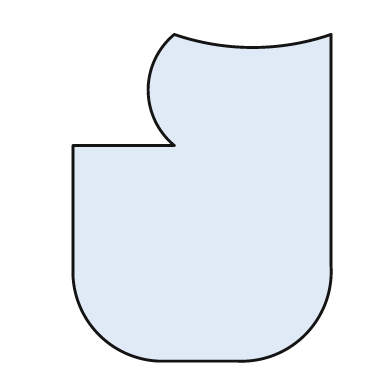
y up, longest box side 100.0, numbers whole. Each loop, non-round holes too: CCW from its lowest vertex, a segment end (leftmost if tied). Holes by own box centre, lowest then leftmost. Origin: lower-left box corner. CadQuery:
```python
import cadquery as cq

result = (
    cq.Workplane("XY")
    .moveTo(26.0, 0.0)
    .lineTo(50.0, 0.0)
    .threePointArc((71.0, 8.0), (79.0, 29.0))
    .lineTo(79.0, 100.0)
    .threePointArc((55.0, 96.0), (31.0, 100.0))
    .threePointArc((23.0, 83.0), (31.0, 66.0))
    .lineTo(0.0, 66.0)
    .lineTo(0.0, 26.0)
    .threePointArc((8.0, 8.0), (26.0, 0.0))
    .close()
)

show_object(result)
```